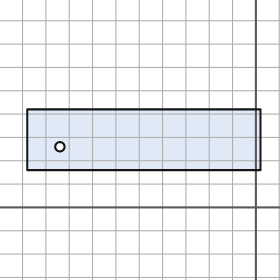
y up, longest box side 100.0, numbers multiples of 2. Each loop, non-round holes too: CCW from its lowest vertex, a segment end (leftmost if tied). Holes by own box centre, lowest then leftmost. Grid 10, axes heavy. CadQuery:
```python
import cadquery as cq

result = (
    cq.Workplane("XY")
    .moveTo(-98.0, 16.0)
    .lineTo(2.0, 16.0)
    .lineTo(2.0, 42.0)
    .lineTo(-98.0, 42.0)
    .close()
    .moveTo(-84.0, 26.0)
    .circle(2.0)
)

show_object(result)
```